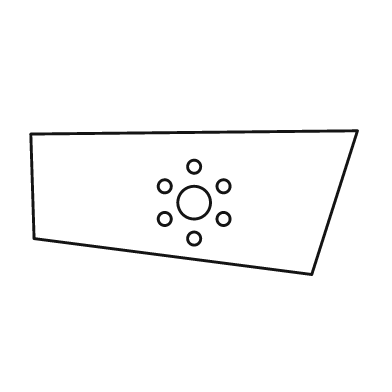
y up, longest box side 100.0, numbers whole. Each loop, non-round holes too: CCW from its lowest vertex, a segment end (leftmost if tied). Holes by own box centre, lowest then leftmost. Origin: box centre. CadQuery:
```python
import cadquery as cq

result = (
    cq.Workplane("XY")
    .moveTo(36.0, -22.0)
    .lineTo(50.0, 22.0)
    .lineTo(-50.0, 21.0)
    .lineTo(-49.0, -11.0)
    .close()
    .moveTo(0.0, -11.0)
    .circle(2.0)
    .moveTo(-9.0, -5.0)
    .circle(2.0)
    .moveTo(9.0, -5.0)
    .circle(2.0)
    .moveTo(0.0, 0.0)
    .circle(5.0)
    .moveTo(-9.0, 5.0)
    .circle(2.0)
    .moveTo(9.0, 5.0)
    .circle(2.0)
    .moveTo(0.0, 11.0)
    .circle(2.0)
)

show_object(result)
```